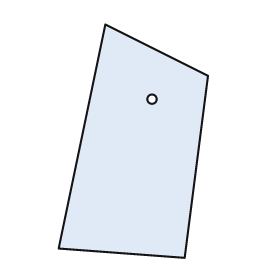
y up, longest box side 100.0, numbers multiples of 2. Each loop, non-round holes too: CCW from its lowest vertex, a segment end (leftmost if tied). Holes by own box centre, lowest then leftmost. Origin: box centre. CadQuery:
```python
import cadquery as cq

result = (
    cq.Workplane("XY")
    .moveTo(22.0, -50.0)
    .lineTo(32.0, 28.0)
    .lineTo(-12.0, 50.0)
    .lineTo(-32.0, -46.0)
    .close()
    .moveTo(8.0, 18.0)
    .circle(2.0)
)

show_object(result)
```